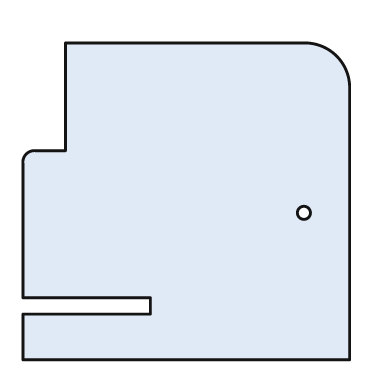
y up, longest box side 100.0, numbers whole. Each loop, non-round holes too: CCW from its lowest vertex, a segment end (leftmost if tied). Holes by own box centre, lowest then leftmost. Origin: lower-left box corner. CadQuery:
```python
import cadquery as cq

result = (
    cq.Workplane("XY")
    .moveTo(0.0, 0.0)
    .lineTo(100.0, 0.0)
    .lineTo(100.0, 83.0)
    .threePointArc((96.0, 93.0), (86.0, 97.0))
    .lineTo(13.0, 97.0)
    .lineTo(13.0, 64.0)
    .lineTo(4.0, 64.0)
    .threePointArc((1.0, 63.0), (0.0, 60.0))
    .lineTo(0.0, 19.0)
    .lineTo(39.0, 19.0)
    .lineTo(39.0, 14.0)
    .lineTo(0.0, 14.0)
    .close()
    .moveTo(86.0, 45.0)
    .circle(2.0)
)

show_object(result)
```